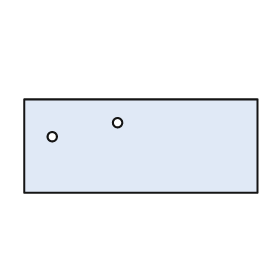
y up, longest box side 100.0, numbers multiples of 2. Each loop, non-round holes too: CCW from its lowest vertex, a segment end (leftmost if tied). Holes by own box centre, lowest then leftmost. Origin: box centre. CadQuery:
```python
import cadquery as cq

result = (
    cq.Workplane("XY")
    .moveTo(-50.0, -20.0)
    .lineTo(50.0, -20.0)
    .lineTo(50.0, 20.0)
    .lineTo(-50.0, 20.0)
    .close()
    .moveTo(-38.0, 4.0)
    .circle(2.0)
    .moveTo(-10.0, 10.0)
    .circle(2.0)
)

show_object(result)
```